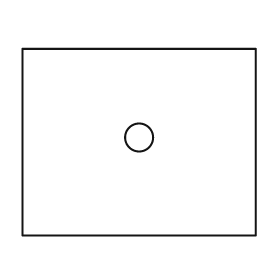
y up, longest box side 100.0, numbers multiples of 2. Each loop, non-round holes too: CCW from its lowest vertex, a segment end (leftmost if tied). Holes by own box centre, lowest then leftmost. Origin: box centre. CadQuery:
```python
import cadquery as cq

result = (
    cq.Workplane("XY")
    .moveTo(-50.0, -40.0)
    .lineTo(50.0, -40.0)
    .lineTo(50.0, 40.0)
    .lineTo(-50.0, 40.0)
    .close()
    .moveTo(0.0, 2.0)
    .circle(6.0)
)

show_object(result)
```